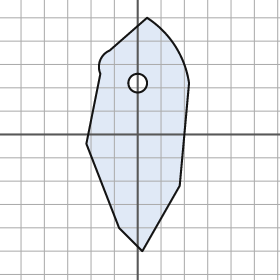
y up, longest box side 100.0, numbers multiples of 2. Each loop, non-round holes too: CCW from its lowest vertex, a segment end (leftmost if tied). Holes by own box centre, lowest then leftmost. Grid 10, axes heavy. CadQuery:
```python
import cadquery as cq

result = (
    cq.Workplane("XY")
    .moveTo(2.0, -50.0)
    .lineTo(18.0, -22.0)
    .lineTo(22.0, 22.0)
    .threePointArc((16.0, 38.0), (4.0, 50.0))
    .lineTo(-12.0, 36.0)
    .threePointArc((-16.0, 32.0), (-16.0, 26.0))
    .lineTo(-22.0, -4.0)
    .lineTo(-8.0, -40.0)
    .close()
    .moveTo(0.0, 22.0)
    .circle(4.0)
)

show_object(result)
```